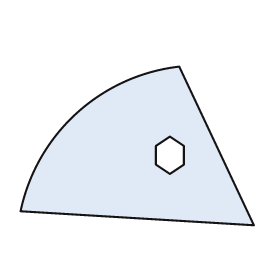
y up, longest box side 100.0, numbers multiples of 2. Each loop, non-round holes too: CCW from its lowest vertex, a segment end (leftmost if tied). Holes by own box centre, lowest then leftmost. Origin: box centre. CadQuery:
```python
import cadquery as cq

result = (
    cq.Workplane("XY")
    .moveTo(50.0, -34.0)
    .lineTo(18.0, 34.0)
    .threePointArc((-26.0, 14.0), (-50.0, -28.0))
    .close()
    .moveTo(14.0, -12.0)
    .lineTo(20.0, -8.0)
    .lineTo(20.0, 0.0)
    .lineTo(14.0, 4.0)
    .lineTo(8.0, 0.0)
    .lineTo(8.0, -8.0)
    .close()
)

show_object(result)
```